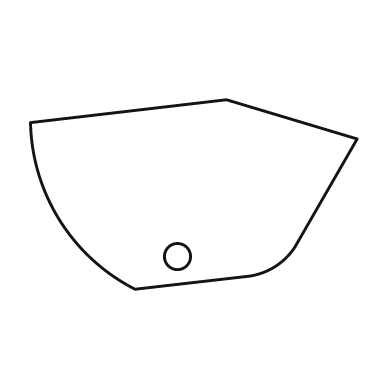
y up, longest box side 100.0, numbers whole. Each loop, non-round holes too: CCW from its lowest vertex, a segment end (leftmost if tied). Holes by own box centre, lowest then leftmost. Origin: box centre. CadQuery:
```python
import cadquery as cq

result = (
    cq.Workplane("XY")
    .moveTo(-18.0, -29.0)
    .lineTo(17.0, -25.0)
    .threePointArc((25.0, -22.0), (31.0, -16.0))
    .lineTo(50.0, 17.0)
    .lineTo(10.0, 29.0)
    .lineTo(-50.0, 22.0)
    .threePointArc((-41.0, -8.0), (-18.0, -29.0))
    .close()
    .moveTo(-5.0, -19.0)
    .circle(4.0)
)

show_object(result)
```